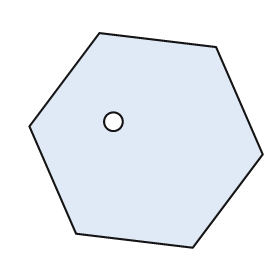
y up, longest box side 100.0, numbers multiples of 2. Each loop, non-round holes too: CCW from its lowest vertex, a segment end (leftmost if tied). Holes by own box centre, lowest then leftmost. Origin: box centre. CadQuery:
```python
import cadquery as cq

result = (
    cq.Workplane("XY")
    .moveTo(20.0, -46.0)
    .lineTo(50.0, -6.0)
    .lineTo(30.0, 40.0)
    .lineTo(-20.0, 46.0)
    .lineTo(-50.0, 6.0)
    .lineTo(-30.0, -40.0)
    .close()
    .moveTo(-14.0, 8.0)
    .circle(4.0)
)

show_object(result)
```